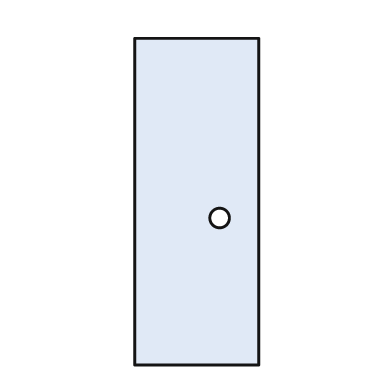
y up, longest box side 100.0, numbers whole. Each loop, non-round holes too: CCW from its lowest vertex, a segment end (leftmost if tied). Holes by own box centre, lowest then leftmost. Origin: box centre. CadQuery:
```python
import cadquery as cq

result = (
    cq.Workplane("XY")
    .moveTo(-19.0, -50.0)
    .lineTo(19.0, -50.0)
    .lineTo(19.0, 50.0)
    .lineTo(-19.0, 50.0)
    .close()
    .moveTo(7.0, -5.0)
    .circle(3.0)
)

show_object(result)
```